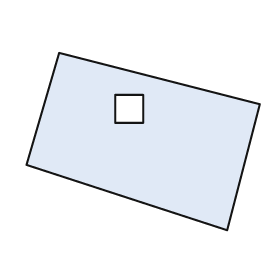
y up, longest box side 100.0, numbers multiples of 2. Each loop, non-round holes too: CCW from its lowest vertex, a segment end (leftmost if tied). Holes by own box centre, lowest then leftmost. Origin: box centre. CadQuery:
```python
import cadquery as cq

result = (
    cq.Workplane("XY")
    .moveTo(36.0, -38.0)
    .lineTo(50.0, 16.0)
    .lineTo(-36.0, 38.0)
    .lineTo(-50.0, -10.0)
    .close()
    .moveTo(-12.0, 8.0)
    .lineTo(0.0, 8.0)
    .lineTo(0.0, 20.0)
    .lineTo(-12.0, 20.0)
    .close()
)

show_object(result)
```